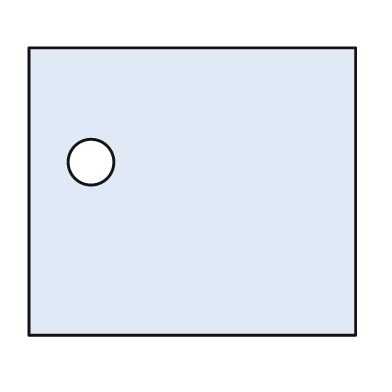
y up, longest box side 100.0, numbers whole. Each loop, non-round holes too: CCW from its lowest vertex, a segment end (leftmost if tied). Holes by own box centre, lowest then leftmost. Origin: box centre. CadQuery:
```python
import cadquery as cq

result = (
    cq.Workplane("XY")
    .moveTo(-50.0, -44.0)
    .lineTo(50.0, -44.0)
    .lineTo(50.0, 44.0)
    .lineTo(-50.0, 44.0)
    .close()
    .moveTo(-31.0, 9.0)
    .circle(7.0)
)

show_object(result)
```